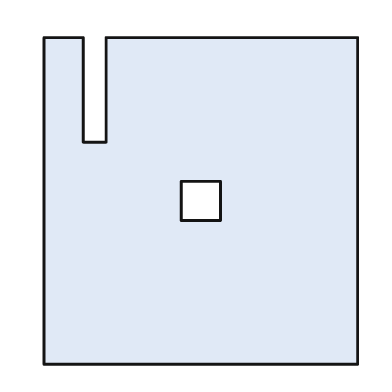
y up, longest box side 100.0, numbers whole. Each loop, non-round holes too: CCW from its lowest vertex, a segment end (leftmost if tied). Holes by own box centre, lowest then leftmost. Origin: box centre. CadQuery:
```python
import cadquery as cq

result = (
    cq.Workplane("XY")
    .moveTo(-48.0, -50.0)
    .lineTo(48.0, -50.0)
    .lineTo(48.0, 50.0)
    .lineTo(-29.0, 50.0)
    .lineTo(-29.0, 18.0)
    .lineTo(-36.0, 18.0)
    .lineTo(-36.0, 50.0)
    .lineTo(-48.0, 50.0)
    .close()
    .moveTo(-6.0, -6.0)
    .lineTo(6.0, -6.0)
    .lineTo(6.0, 6.0)
    .lineTo(-6.0, 6.0)
    .close()
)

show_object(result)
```